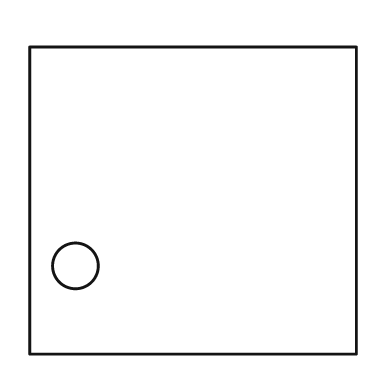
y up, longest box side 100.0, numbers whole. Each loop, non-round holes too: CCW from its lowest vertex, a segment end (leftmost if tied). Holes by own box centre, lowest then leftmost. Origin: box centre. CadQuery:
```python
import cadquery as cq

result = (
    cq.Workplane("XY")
    .moveTo(-50.0, -47.0)
    .lineTo(50.0, -47.0)
    .lineTo(50.0, 47.0)
    .lineTo(-50.0, 47.0)
    .close()
    .moveTo(-36.0, -20.0)
    .circle(7.0)
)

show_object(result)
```